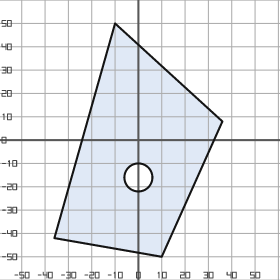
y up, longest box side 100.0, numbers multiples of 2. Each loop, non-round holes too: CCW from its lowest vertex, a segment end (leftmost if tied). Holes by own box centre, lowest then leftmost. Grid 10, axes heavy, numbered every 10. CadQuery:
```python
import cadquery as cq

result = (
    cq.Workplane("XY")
    .moveTo(10.0, -50.0)
    .lineTo(36.0, 8.0)
    .lineTo(-10.0, 50.0)
    .lineTo(-36.0, -42.0)
    .close()
    .moveTo(0.0, -16.0)
    .circle(6.0)
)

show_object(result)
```